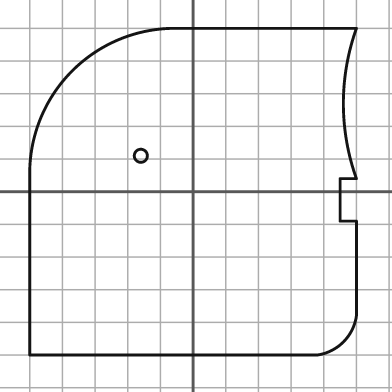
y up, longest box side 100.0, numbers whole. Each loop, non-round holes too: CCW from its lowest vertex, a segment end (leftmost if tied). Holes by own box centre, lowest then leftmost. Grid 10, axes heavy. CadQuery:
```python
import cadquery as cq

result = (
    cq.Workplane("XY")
    .moveTo(-50.0, -50.0)
    .lineTo(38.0, -50.0)
    .threePointArc((46.0, -46.0), (50.0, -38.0))
    .lineTo(50.0, -9.0)
    .lineTo(45.0, -9.0)
    .lineTo(45.0, 4.0)
    .lineTo(50.0, 4.0)
    .threePointArc((46.0, 27.0), (50.0, 50.0))
    .lineTo(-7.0, 50.0)
    .threePointArc((-37.0, 37.0), (-50.0, 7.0))
    .close()
    .moveTo(-16.0, 11.0)
    .circle(2.0)
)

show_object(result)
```